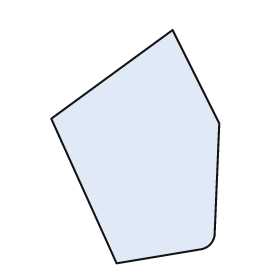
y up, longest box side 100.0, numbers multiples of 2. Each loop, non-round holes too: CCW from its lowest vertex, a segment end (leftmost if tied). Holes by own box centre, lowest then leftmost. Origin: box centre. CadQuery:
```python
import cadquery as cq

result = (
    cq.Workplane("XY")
    .moveTo(-8.0, -50.0)
    .lineTo(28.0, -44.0)
    .threePointArc((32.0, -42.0), (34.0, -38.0))
    .lineTo(36.0, 10.0)
    .lineTo(16.0, 50.0)
    .lineTo(-36.0, 12.0)
    .close()
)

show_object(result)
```